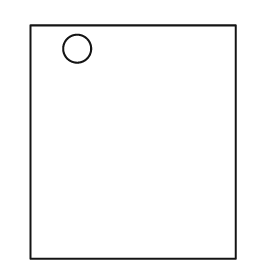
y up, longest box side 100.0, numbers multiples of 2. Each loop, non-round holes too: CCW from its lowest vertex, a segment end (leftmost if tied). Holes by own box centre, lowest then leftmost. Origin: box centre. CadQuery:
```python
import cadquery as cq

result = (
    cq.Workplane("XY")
    .moveTo(-44.0, -50.0)
    .lineTo(44.0, -50.0)
    .lineTo(44.0, 50.0)
    .lineTo(-44.0, 50.0)
    .close()
    .moveTo(-24.0, 40.0)
    .circle(6.0)
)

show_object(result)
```